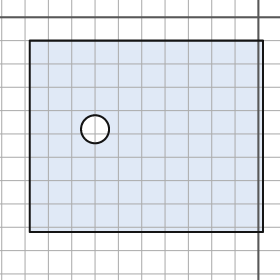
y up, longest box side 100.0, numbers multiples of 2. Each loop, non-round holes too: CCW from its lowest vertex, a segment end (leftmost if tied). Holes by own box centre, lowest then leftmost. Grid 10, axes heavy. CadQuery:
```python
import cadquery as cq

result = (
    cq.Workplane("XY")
    .moveTo(-98.0, -92.0)
    .lineTo(2.0, -92.0)
    .lineTo(2.0, -10.0)
    .lineTo(-98.0, -10.0)
    .close()
    .moveTo(-70.0, -48.0)
    .circle(6.0)
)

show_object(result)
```